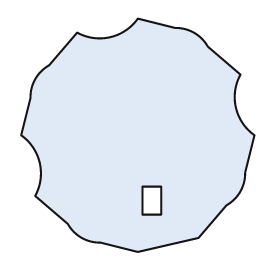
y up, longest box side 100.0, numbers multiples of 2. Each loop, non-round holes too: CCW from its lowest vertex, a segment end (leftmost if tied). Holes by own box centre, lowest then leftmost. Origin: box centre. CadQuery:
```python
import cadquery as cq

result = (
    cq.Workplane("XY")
    .moveTo(0.0, -50.0)
    .lineTo(26.0, -44.0)
    .lineTo(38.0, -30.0)
    .threePointArc((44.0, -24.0), (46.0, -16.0))
    .lineTo(50.0, 0.0)
    .threePointArc((42.0, 12.0), (44.0, 26.0))
    .lineTo(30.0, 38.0)
    .threePointArc((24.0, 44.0), (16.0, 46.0))
    .lineTo(0.0, 50.0)
    .threePointArc((-12.0, 42.0), (-26.0, 44.0))
    .lineTo(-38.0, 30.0)
    .threePointArc((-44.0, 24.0), (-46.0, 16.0))
    .lineTo(-50.0, 0.0)
    .threePointArc((-42.0, -12.0), (-44.0, -26.0))
    .lineTo(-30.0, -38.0)
    .threePointArc((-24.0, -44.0), (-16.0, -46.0))
    .close()
    .moveTo(2.0, -34.0)
    .lineTo(10.0, -34.0)
    .lineTo(10.0, -22.0)
    .lineTo(2.0, -22.0)
    .close()
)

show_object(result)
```